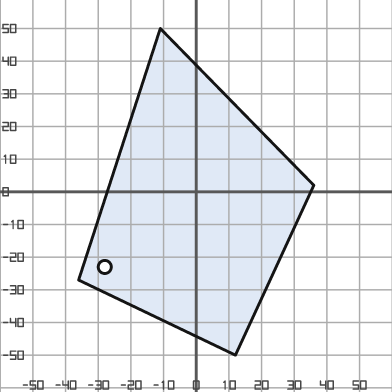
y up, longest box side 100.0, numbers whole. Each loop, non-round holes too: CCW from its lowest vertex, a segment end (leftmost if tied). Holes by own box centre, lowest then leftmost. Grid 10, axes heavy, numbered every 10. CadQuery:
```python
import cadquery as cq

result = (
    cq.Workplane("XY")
    .moveTo(12.0, -50.0)
    .lineTo(36.0, 2.0)
    .lineTo(-11.0, 50.0)
    .lineTo(-36.0, -27.0)
    .close()
    .moveTo(-28.0, -23.0)
    .circle(2.0)
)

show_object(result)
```